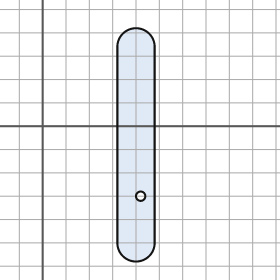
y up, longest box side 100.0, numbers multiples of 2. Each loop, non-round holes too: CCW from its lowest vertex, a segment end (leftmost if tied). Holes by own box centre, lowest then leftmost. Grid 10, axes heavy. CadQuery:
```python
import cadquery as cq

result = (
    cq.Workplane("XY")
    .moveTo(32.0, -50.0)
    .threePointArc((40.0, -58.0), (48.0, -50.0))
    .lineTo(48.0, 34.0)
    .threePointArc((40.0, 42.0), (32.0, 34.0))
    .close()
    .moveTo(42.0, -30.0)
    .circle(2.0)
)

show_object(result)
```